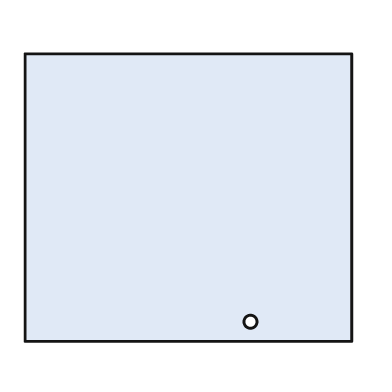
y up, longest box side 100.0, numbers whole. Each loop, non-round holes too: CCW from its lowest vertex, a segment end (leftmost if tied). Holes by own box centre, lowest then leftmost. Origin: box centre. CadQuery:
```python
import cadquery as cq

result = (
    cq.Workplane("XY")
    .moveTo(-50.0, -44.0)
    .lineTo(50.0, -44.0)
    .lineTo(50.0, 44.0)
    .lineTo(-50.0, 44.0)
    .close()
    .moveTo(19.0, -38.0)
    .circle(2.0)
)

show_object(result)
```